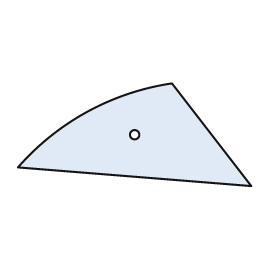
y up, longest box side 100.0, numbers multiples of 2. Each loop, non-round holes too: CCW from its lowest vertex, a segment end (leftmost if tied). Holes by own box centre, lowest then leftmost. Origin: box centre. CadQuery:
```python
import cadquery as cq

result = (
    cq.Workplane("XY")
    .moveTo(50.0, -22.0)
    .lineTo(16.0, 22.0)
    .threePointArc((-20.0, 10.0), (-50.0, -14.0))
    .close()
    .moveTo(0.0, 0.0)
    .circle(2.0)
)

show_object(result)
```